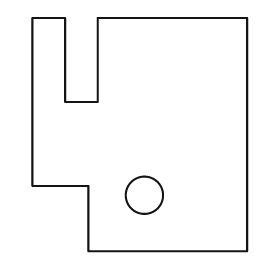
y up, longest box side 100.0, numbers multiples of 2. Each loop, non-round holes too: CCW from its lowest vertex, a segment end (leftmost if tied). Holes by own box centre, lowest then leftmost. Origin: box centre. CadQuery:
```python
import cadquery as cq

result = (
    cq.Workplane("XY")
    .moveTo(-22.0, -50.0)
    .lineTo(46.0, -50.0)
    .lineTo(46.0, 50.0)
    .lineTo(-18.0, 50.0)
    .lineTo(-18.0, 14.0)
    .lineTo(-32.0, 14.0)
    .lineTo(-32.0, 50.0)
    .lineTo(-46.0, 50.0)
    .lineTo(-46.0, -22.0)
    .lineTo(-22.0, -22.0)
    .close()
    .moveTo(2.0, -26.0)
    .circle(8.0)
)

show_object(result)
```